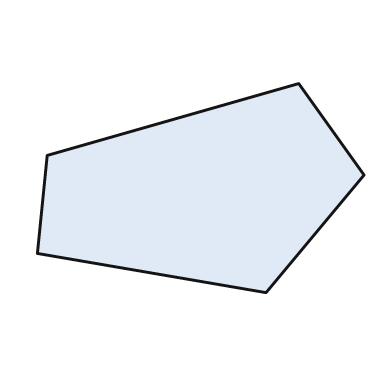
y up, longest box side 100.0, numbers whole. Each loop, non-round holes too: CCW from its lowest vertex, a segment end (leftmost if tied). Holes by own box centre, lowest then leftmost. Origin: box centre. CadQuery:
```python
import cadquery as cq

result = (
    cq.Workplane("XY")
    .moveTo(20.0, -32.0)
    .lineTo(50.0, 4.0)
    .lineTo(30.0, 32.0)
    .lineTo(-47.0, 10.0)
    .lineTo(-50.0, -20.0)
    .close()
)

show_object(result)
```